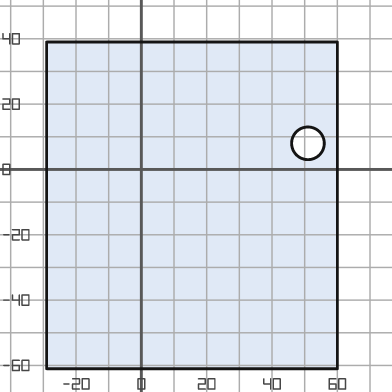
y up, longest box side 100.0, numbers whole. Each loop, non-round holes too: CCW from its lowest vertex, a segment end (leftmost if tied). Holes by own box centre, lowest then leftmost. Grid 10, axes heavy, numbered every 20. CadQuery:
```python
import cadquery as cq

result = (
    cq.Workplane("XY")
    .moveTo(-29.0, -61.0)
    .lineTo(60.0, -61.0)
    .lineTo(60.0, 39.0)
    .lineTo(-29.0, 39.0)
    .close()
    .moveTo(51.0, 8.0)
    .circle(5.0)
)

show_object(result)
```